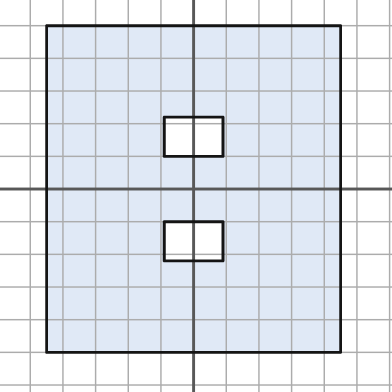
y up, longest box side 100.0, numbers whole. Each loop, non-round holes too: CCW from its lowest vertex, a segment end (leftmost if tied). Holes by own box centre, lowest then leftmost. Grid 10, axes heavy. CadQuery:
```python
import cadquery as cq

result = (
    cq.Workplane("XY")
    .moveTo(-45.0, -50.0)
    .lineTo(45.0, -50.0)
    .lineTo(45.0, 50.0)
    .lineTo(-45.0, 50.0)
    .close()
    .moveTo(-9.0, -22.0)
    .lineTo(9.0, -22.0)
    .lineTo(9.0, -10.0)
    .lineTo(-9.0, -10.0)
    .close()
    .moveTo(-9.0, 10.0)
    .lineTo(9.0, 10.0)
    .lineTo(9.0, 22.0)
    .lineTo(-9.0, 22.0)
    .close()
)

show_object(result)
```